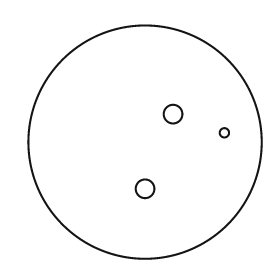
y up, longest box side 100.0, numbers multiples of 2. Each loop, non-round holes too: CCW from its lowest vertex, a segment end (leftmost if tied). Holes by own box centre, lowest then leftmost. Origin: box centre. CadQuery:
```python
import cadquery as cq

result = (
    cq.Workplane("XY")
    .moveTo(0.0, 0.0)
    .circle(50.0)
    .moveTo(0.0, -20.0)
    .circle(4.0)
    .moveTo(34.0, 4.0)
    .circle(2.0)
    .moveTo(12.0, 12.0)
    .circle(4.0)
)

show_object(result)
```